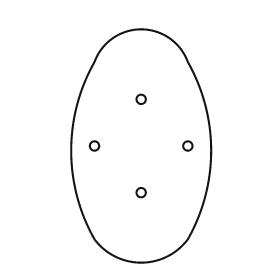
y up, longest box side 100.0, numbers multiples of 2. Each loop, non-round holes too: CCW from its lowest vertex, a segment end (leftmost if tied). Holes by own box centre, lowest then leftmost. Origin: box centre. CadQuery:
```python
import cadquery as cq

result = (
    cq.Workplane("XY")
    .moveTo(-20.0, -40.0)
    .threePointArc((0.0, -50.0), (20.0, -40.0))
    .threePointArc((30.0, -2.0), (20.0, 36.0))
    .threePointArc((0.0, 50.0), (-20.0, 36.0))
    .threePointArc((-30.0, -2.0), (-20.0, -40.0))
    .close()
    .moveTo(0.0, -20.0)
    .circle(2.0)
    .moveTo(-20.0, 0.0)
    .circle(2.0)
    .moveTo(20.0, 0.0)
    .circle(2.0)
    .moveTo(0.0, 20.0)
    .circle(2.0)
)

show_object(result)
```